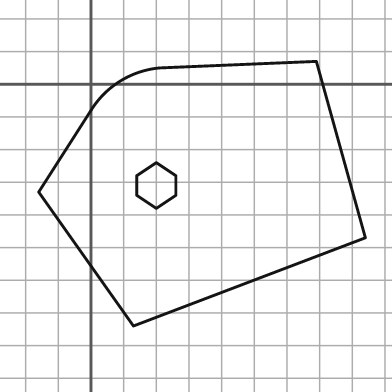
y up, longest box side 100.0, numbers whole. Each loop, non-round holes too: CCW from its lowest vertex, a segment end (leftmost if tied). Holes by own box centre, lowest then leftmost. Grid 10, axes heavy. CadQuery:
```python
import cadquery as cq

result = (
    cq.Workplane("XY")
    .moveTo(13.0, -74.0)
    .lineTo(84.0, -47.0)
    .lineTo(69.0, 7.0)
    .lineTo(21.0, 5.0)
    .threePointArc((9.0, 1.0), (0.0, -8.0))
    .lineTo(-16.0, -33.0)
    .close()
    .moveTo(20.0, -38.0)
    .lineTo(26.0, -34.0)
    .lineTo(26.0, -28.0)
    .lineTo(20.0, -24.0)
    .lineTo(14.0, -28.0)
    .lineTo(14.0, -34.0)
    .close()
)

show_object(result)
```